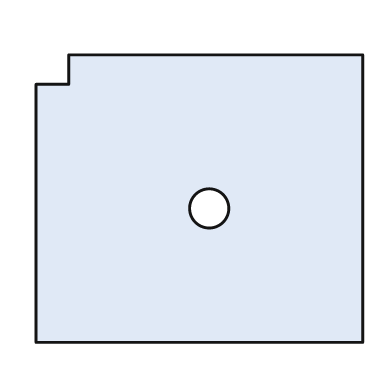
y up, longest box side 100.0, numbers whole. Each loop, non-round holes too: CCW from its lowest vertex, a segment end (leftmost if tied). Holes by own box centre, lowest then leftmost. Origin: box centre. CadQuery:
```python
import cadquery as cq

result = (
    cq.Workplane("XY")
    .moveTo(-50.0, -44.0)
    .lineTo(50.0, -44.0)
    .lineTo(50.0, 44.0)
    .lineTo(-40.0, 44.0)
    .lineTo(-40.0, 35.0)
    .lineTo(-50.0, 35.0)
    .close()
    .moveTo(3.0, -3.0)
    .circle(6.0)
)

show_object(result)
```